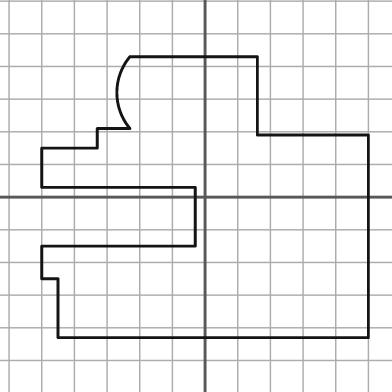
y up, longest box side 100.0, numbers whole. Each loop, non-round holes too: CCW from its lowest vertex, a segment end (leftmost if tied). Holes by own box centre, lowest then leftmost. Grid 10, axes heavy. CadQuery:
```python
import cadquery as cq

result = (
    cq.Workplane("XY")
    .moveTo(-45.0, -43.0)
    .lineTo(50.0, -43.0)
    .lineTo(50.0, 19.0)
    .lineTo(16.0, 19.0)
    .lineTo(16.0, 43.0)
    .lineTo(-23.0, 43.0)
    .threePointArc((-27.0, 32.0), (-23.0, 21.0))
    .lineTo(-33.0, 21.0)
    .lineTo(-33.0, 15.0)
    .lineTo(-50.0, 15.0)
    .lineTo(-50.0, 3.0)
    .lineTo(-3.0, 3.0)
    .lineTo(-3.0, -15.0)
    .lineTo(-50.0, -15.0)
    .lineTo(-50.0, -25.0)
    .lineTo(-45.0, -25.0)
    .close()
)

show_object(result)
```